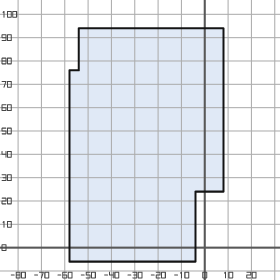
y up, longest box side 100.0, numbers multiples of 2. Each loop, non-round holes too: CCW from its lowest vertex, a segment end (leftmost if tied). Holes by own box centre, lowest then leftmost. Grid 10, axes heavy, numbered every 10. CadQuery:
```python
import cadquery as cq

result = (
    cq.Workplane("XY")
    .moveTo(-58.0, -6.0)
    .lineTo(-4.0, -6.0)
    .lineTo(-4.0, 24.0)
    .lineTo(8.0, 24.0)
    .lineTo(8.0, 94.0)
    .lineTo(-54.0, 94.0)
    .lineTo(-54.0, 76.0)
    .lineTo(-58.0, 76.0)
    .close()
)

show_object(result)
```